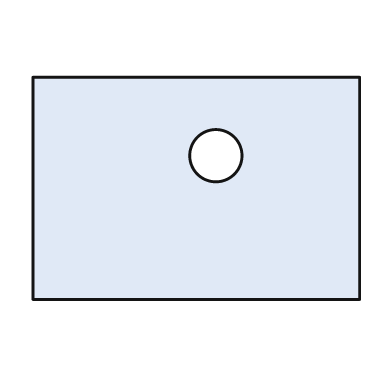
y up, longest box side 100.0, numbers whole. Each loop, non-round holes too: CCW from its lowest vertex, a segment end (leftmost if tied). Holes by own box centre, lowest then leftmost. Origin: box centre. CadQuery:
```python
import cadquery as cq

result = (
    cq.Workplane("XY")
    .moveTo(-50.0, -34.0)
    .lineTo(50.0, -34.0)
    .lineTo(50.0, 34.0)
    .lineTo(-50.0, 34.0)
    .close()
    .moveTo(6.0, 10.0)
    .circle(8.0)
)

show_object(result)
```